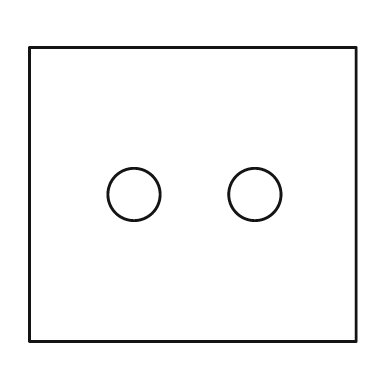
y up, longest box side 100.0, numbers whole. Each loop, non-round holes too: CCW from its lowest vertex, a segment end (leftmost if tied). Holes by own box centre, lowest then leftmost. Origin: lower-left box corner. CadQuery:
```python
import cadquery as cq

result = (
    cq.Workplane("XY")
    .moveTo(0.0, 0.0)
    .lineTo(100.0, 0.0)
    .lineTo(100.0, 90.0)
    .lineTo(0.0, 90.0)
    .close()
    .moveTo(32.0, 45.0)
    .circle(8.0)
    .moveTo(69.0, 45.0)
    .circle(8.0)
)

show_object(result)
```